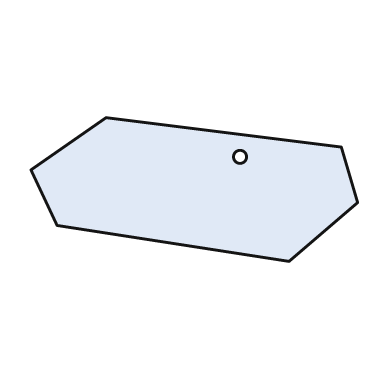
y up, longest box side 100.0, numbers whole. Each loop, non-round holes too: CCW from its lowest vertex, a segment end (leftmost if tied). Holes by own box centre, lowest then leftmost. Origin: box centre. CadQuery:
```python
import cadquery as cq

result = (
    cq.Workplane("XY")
    .moveTo(29.0, -22.0)
    .lineTo(50.0, -4.0)
    .lineTo(45.0, 13.0)
    .lineTo(-27.0, 22.0)
    .lineTo(-50.0, 6.0)
    .lineTo(-42.0, -11.0)
    .close()
    .moveTo(14.0, 10.0)
    .circle(2.0)
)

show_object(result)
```